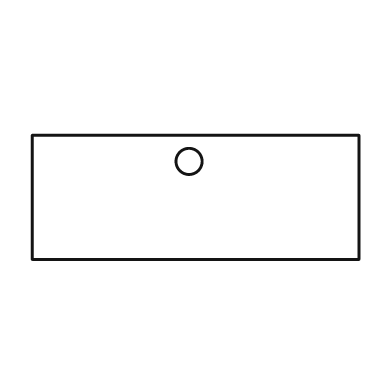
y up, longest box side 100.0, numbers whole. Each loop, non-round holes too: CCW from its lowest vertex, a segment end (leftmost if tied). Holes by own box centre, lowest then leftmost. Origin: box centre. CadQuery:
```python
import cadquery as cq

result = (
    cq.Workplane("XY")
    .moveTo(-50.0, -19.0)
    .lineTo(50.0, -19.0)
    .lineTo(50.0, 19.0)
    .lineTo(-50.0, 19.0)
    .close()
    .moveTo(-2.0, 11.0)
    .circle(4.0)
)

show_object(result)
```